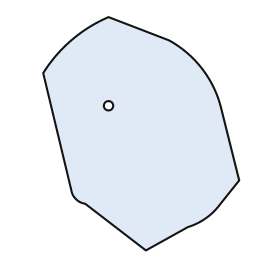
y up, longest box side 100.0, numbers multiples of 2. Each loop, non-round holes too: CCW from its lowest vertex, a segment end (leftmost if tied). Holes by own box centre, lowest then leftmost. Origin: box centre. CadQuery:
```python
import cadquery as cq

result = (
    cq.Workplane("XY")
    .moveTo(2.0, -50.0)
    .lineTo(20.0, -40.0)
    .threePointArc((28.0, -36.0), (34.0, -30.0))
    .lineTo(42.0, -20.0)
    .lineTo(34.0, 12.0)
    .threePointArc((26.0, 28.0), (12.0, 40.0))
    .lineTo(-14.0, 50.0)
    .threePointArc((-30.0, 40.0), (-42.0, 26.0))
    .lineTo(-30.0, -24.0)
    .threePointArc((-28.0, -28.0), (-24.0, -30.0))
    .close()
    .moveTo(-14.0, 12.0)
    .circle(2.0)
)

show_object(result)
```